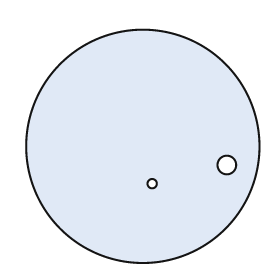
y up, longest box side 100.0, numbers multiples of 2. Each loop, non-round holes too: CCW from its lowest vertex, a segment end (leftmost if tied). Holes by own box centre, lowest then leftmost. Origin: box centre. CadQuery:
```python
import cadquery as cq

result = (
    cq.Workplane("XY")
    .moveTo(0.0, 0.0)
    .circle(50.0)
    .moveTo(4.0, -16.0)
    .circle(2.0)
    .moveTo(36.0, -8.0)
    .circle(4.0)
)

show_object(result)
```